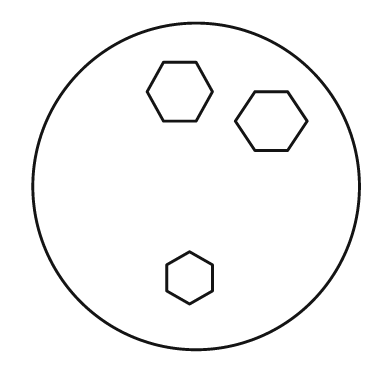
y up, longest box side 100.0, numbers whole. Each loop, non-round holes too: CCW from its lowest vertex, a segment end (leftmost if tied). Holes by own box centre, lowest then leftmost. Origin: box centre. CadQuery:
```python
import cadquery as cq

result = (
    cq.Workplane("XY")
    .moveTo(0.0, 0.0)
    .circle(50.0)
    .moveTo(-2.0, -36.0)
    .lineTo(5.0, -32.0)
    .lineTo(5.0, -24.0)
    .lineTo(-2.0, -20.0)
    .lineTo(-9.0, -24.0)
    .lineTo(-9.0, -32.0)
    .close()
    .moveTo(18.0, 11.0)
    .lineTo(28.0, 11.0)
    .lineTo(34.0, 20.0)
    .lineTo(28.0, 29.0)
    .lineTo(18.0, 29.0)
    .lineTo(12.0, 20.0)
    .close()
    .moveTo(-10.0, 20.0)
    .lineTo(0.0, 20.0)
    .lineTo(5.0, 29.0)
    .lineTo(0.0, 38.0)
    .lineTo(-10.0, 38.0)
    .lineTo(-15.0, 29.0)
    .close()
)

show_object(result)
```